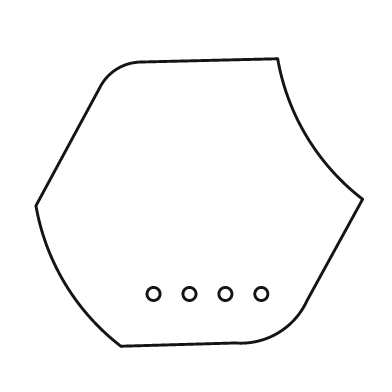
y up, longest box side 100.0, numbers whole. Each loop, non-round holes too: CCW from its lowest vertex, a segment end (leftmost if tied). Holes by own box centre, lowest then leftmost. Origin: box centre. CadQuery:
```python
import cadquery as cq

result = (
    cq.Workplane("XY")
    .moveTo(-24.0, -44.0)
    .lineTo(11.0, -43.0)
    .threePointArc((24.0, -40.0), (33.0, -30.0))
    .lineTo(50.0, 1.0)
    .threePointArc((33.0, 20.0), (24.0, 44.0))
    .lineTo(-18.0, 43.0)
    .threePointArc((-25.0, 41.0), (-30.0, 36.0))
    .lineTo(-50.0, -1.0)
    .threePointArc((-41.0, -25.0), (-24.0, -44.0))
    .close()
    .moveTo(-14.0, -28.0)
    .circle(2.0)
    .moveTo(-3.0, -28.0)
    .circle(2.0)
    .moveTo(8.0, -28.0)
    .circle(2.0)
    .moveTo(19.0, -28.0)
    .circle(2.0)
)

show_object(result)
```